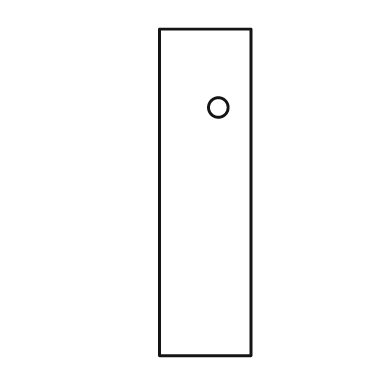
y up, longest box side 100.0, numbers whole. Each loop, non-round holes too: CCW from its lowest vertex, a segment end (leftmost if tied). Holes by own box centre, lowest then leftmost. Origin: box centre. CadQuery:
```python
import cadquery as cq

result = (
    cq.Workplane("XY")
    .moveTo(-14.0, -50.0)
    .lineTo(14.0, -50.0)
    .lineTo(14.0, 50.0)
    .lineTo(-14.0, 50.0)
    .close()
    .moveTo(4.0, 26.0)
    .circle(3.0)
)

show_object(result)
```